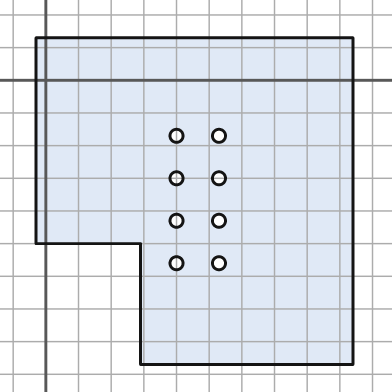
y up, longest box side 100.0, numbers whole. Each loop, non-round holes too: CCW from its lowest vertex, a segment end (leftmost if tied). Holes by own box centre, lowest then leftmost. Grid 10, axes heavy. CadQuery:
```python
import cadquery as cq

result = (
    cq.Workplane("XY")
    .moveTo(29.0, -87.0)
    .lineTo(94.0, -87.0)
    .lineTo(94.0, 13.0)
    .lineTo(-3.0, 13.0)
    .lineTo(-3.0, -50.0)
    .lineTo(29.0, -50.0)
    .close()
    .moveTo(40.0, -56.0)
    .circle(2.0)
    .moveTo(53.0, -56.0)
    .circle(2.0)
    .moveTo(40.0, -43.0)
    .circle(2.0)
    .moveTo(53.0, -43.0)
    .circle(2.0)
    .moveTo(40.0, -30.0)
    .circle(2.0)
    .moveTo(53.0, -30.0)
    .circle(2.0)
    .moveTo(40.0, -17.0)
    .circle(2.0)
    .moveTo(53.0, -17.0)
    .circle(2.0)
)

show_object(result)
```